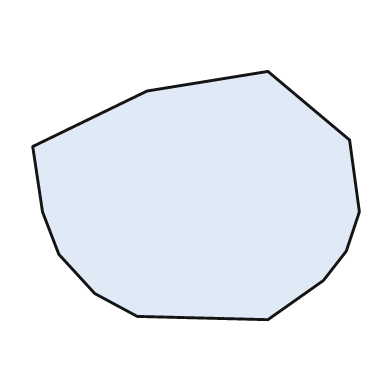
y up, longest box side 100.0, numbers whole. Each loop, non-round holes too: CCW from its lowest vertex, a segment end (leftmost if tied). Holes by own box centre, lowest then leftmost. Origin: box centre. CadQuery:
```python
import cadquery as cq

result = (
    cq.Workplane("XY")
    .moveTo(22.0, -38.0)
    .lineTo(39.0, -26.0)
    .lineTo(46.0, -17.0)
    .lineTo(50.0, -5.0)
    .lineTo(47.0, 17.0)
    .lineTo(22.0, 38.0)
    .lineTo(-15.0, 32.0)
    .lineTo(-50.0, 15.0)
    .lineTo(-47.0, -5.0)
    .lineTo(-42.0, -18.0)
    .lineTo(-31.0, -30.0)
    .lineTo(-18.0, -37.0)
    .close()
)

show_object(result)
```